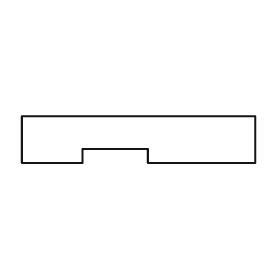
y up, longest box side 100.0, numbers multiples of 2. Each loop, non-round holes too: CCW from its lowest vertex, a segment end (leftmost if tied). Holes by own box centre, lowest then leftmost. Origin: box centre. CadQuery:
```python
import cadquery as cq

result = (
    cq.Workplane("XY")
    .moveTo(-50.0, -10.0)
    .lineTo(-24.0, -10.0)
    .lineTo(-24.0, -4.0)
    .lineTo(4.0, -4.0)
    .lineTo(4.0, -10.0)
    .lineTo(50.0, -10.0)
    .lineTo(50.0, 10.0)
    .lineTo(-50.0, 10.0)
    .close()
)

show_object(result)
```